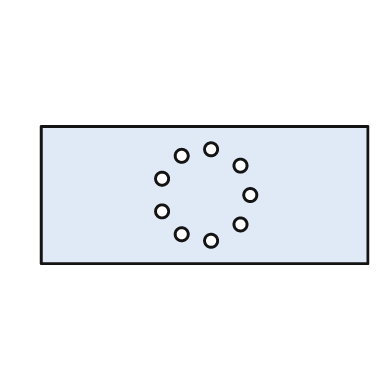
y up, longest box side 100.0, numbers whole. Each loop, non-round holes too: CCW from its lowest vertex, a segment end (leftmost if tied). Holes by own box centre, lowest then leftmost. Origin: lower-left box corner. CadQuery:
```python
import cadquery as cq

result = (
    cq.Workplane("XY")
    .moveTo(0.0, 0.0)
    .lineTo(100.0, 0.0)
    .lineTo(100.0, 42.0)
    .lineTo(0.0, 42.0)
    .close()
    .moveTo(52.0, 7.0)
    .circle(2.0)
    .moveTo(43.0, 9.0)
    .circle(2.0)
    .moveTo(61.0, 12.0)
    .circle(2.0)
    .moveTo(37.0, 16.0)
    .circle(2.0)
    .moveTo(64.0, 21.0)
    .circle(2.0)
    .moveTo(37.0, 26.0)
    .circle(2.0)
    .moveTo(61.0, 30.0)
    .circle(2.0)
    .moveTo(43.0, 33.0)
    .circle(2.0)
    .moveTo(52.0, 35.0)
    .circle(2.0)
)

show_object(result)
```